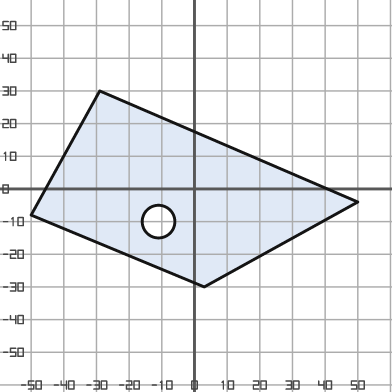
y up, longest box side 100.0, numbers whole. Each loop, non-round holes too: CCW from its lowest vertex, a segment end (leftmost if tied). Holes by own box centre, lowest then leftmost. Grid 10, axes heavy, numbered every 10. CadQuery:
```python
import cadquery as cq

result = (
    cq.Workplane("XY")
    .moveTo(3.0, -30.0)
    .lineTo(50.0, -4.0)
    .lineTo(-29.0, 30.0)
    .lineTo(-50.0, -8.0)
    .close()
    .moveTo(-11.0, -10.0)
    .circle(5.0)
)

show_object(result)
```